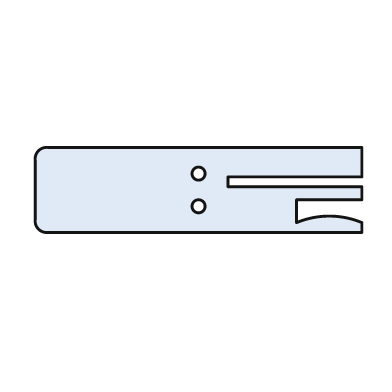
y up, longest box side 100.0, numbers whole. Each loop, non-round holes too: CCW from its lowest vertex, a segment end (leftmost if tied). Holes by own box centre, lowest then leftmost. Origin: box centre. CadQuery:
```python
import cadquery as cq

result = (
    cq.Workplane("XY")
    .moveTo(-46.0, -13.0)
    .lineTo(50.0, -13.0)
    .lineTo(50.0, -10.0)
    .threePointArc((40.0, -8.0), (30.0, -10.0))
    .lineTo(30.0, -3.0)
    .lineTo(50.0, -3.0)
    .lineTo(50.0, 1.0)
    .lineTo(9.0, 1.0)
    .lineTo(9.0, 4.0)
    .lineTo(50.0, 4.0)
    .lineTo(50.0, 13.0)
    .lineTo(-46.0, 13.0)
    .threePointArc((-49.0, 12.0), (-50.0, 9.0))
    .lineTo(-50.0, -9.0)
    .threePointArc((-49.0, -12.0), (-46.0, -13.0))
    .close()
    .moveTo(0.0, -5.0)
    .circle(2.0)
    .moveTo(0.0, 5.0)
    .circle(2.0)
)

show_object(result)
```